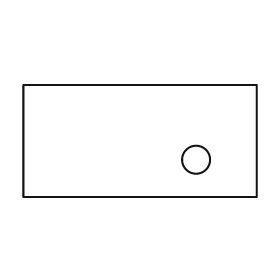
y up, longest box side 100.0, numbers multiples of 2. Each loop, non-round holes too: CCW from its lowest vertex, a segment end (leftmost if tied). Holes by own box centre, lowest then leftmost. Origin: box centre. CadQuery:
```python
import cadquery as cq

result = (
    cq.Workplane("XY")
    .moveTo(-50.0, -24.0)
    .lineTo(50.0, -24.0)
    .lineTo(50.0, 24.0)
    .lineTo(-50.0, 24.0)
    .close()
    .moveTo(24.0, -8.0)
    .circle(6.0)
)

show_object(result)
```